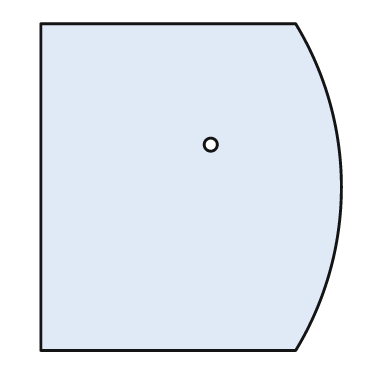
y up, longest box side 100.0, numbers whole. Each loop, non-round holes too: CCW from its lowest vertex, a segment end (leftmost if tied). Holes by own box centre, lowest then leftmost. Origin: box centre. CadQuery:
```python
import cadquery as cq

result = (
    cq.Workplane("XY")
    .moveTo(-46.0, -50.0)
    .lineTo(32.0, -50.0)
    .threePointArc((46.0, 0.0), (32.0, 50.0))
    .lineTo(-46.0, 50.0)
    .close()
    .moveTo(6.0, 13.0)
    .circle(2.0)
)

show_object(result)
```